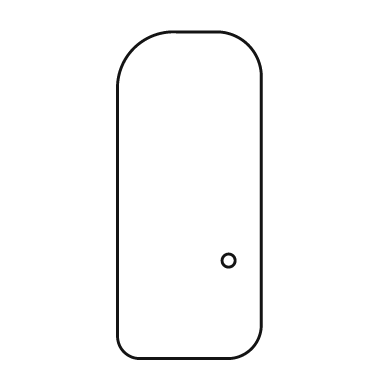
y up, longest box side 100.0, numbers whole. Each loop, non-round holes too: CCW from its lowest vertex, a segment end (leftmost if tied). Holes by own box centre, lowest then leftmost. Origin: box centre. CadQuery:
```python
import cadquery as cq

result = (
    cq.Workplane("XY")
    .moveTo(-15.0, -50.0)
    .lineTo(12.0, -50.0)
    .threePointArc((19.0, -47.0), (22.0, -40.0))
    .lineTo(22.0, 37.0)
    .threePointArc((18.0, 46.0), (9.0, 50.0))
    .lineTo(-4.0, 50.0)
    .threePointArc((-17.0, 45.0), (-22.0, 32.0))
    .lineTo(-22.0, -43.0)
    .threePointArc((-20.0, -48.0), (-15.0, -50.0))
    .close()
    .moveTo(12.0, -20.0)
    .circle(2.0)
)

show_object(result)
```